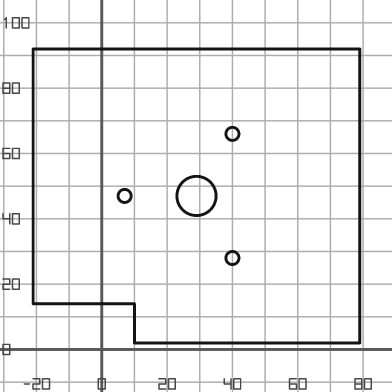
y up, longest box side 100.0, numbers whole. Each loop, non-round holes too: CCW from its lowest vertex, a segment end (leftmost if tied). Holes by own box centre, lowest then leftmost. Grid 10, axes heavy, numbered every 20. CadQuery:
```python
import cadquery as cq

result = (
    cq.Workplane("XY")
    .moveTo(10.0, 2.0)
    .lineTo(79.0, 2.0)
    .lineTo(79.0, 92.0)
    .lineTo(-21.0, 92.0)
    .lineTo(-21.0, 14.0)
    .lineTo(10.0, 14.0)
    .close()
    .moveTo(40.0, 28.0)
    .circle(2.0)
    .moveTo(7.0, 47.0)
    .circle(2.0)
    .moveTo(29.0, 47.0)
    .circle(6.0)
    .moveTo(40.0, 66.0)
    .circle(2.0)
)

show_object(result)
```